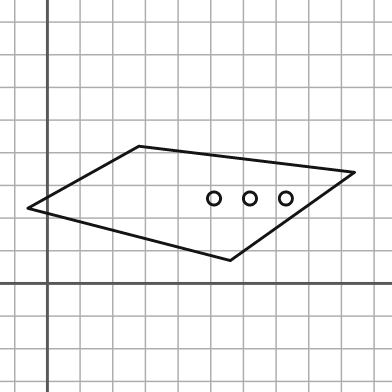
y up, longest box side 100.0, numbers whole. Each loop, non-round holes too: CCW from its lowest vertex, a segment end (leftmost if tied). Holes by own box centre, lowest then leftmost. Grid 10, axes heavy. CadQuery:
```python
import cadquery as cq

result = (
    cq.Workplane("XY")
    .moveTo(56.0, 7.0)
    .lineTo(94.0, 34.0)
    .lineTo(28.0, 42.0)
    .lineTo(-6.0, 23.0)
    .close()
    .moveTo(51.0, 26.0)
    .circle(2.0)
    .moveTo(62.0, 26.0)
    .circle(2.0)
    .moveTo(73.0, 26.0)
    .circle(2.0)
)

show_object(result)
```